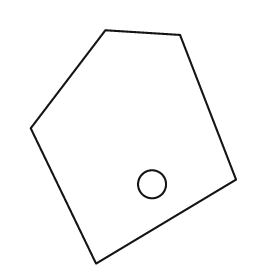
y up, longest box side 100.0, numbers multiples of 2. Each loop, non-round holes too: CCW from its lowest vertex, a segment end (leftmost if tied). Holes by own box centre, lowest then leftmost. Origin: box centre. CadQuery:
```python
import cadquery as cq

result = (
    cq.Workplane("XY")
    .moveTo(-16.0, -50.0)
    .lineTo(44.0, -14.0)
    .lineTo(20.0, 48.0)
    .lineTo(-12.0, 50.0)
    .lineTo(-44.0, 8.0)
    .close()
    .moveTo(8.0, -16.0)
    .circle(6.0)
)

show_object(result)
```